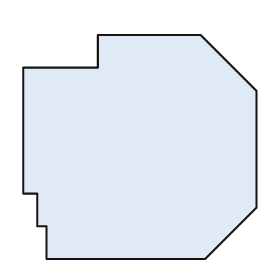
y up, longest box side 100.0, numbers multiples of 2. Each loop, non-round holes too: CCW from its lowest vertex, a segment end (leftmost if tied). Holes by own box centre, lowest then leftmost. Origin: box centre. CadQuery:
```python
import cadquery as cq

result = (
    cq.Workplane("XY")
    .moveTo(-40.0, -48.0)
    .lineTo(28.0, -48.0)
    .lineTo(50.0, -26.0)
    .lineTo(50.0, 24.0)
    .lineTo(26.0, 48.0)
    .lineTo(-18.0, 48.0)
    .lineTo(-18.0, 34.0)
    .lineTo(-50.0, 34.0)
    .lineTo(-50.0, -20.0)
    .lineTo(-44.0, -20.0)
    .lineTo(-44.0, -34.0)
    .lineTo(-40.0, -34.0)
    .close()
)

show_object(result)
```